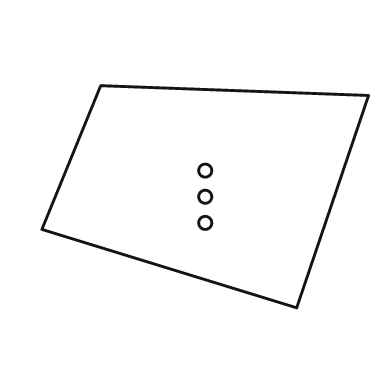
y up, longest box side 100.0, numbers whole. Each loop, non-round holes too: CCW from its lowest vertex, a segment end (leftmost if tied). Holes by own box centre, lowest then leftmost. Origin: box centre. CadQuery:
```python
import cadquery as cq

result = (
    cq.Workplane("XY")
    .moveTo(28.0, -34.0)
    .lineTo(50.0, 31.0)
    .lineTo(-32.0, 34.0)
    .lineTo(-50.0, -10.0)
    .close()
    .moveTo(0.0, -8.0)
    .circle(2.0)
    .moveTo(0.0, 0.0)
    .circle(2.0)
    .moveTo(0.0, 8.0)
    .circle(2.0)
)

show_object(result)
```